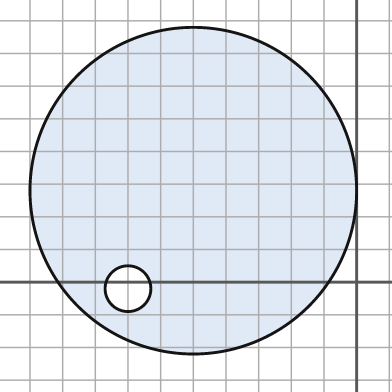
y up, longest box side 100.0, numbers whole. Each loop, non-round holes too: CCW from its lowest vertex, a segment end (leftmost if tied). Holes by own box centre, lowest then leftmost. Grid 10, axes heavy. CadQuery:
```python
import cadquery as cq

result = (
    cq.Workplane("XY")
    .moveTo(-50.0, 28.0)
    .circle(50.0)
    .moveTo(-70.0, -2.0)
    .circle(7.0)
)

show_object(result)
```